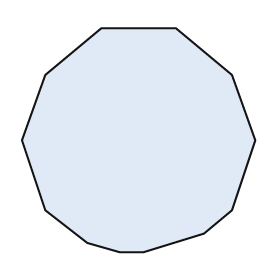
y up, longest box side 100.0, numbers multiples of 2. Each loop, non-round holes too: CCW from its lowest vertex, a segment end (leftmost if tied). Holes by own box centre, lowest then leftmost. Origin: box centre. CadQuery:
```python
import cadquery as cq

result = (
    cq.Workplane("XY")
    .moveTo(-8.0, -48.0)
    .lineTo(2.0, -48.0)
    .lineTo(28.0, -40.0)
    .lineTo(40.0, -30.0)
    .lineTo(50.0, 0.0)
    .lineTo(40.0, 28.0)
    .lineTo(16.0, 48.0)
    .lineTo(-16.0, 48.0)
    .lineTo(-40.0, 28.0)
    .lineTo(-50.0, 0.0)
    .lineTo(-40.0, -30.0)
    .lineTo(-22.0, -44.0)
    .close()
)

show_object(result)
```